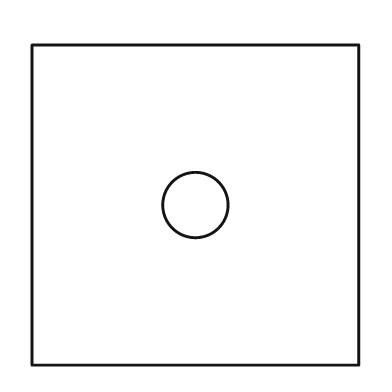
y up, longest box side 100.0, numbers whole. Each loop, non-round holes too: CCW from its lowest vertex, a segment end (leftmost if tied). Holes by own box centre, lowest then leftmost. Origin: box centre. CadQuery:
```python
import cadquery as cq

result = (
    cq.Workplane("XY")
    .moveTo(-50.0, -49.0)
    .lineTo(50.0, -49.0)
    .lineTo(50.0, 49.0)
    .lineTo(-50.0, 49.0)
    .close()
    .moveTo(0.0, 0.0)
    .circle(10.0)
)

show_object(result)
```